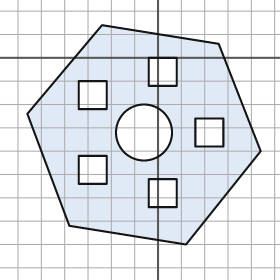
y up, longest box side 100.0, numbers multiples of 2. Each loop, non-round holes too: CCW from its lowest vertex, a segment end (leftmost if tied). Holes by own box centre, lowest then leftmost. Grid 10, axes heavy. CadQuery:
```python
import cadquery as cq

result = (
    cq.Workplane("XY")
    .moveTo(12.0, -80.0)
    .lineTo(44.0, -40.0)
    .lineTo(26.0, 6.0)
    .lineTo(-24.0, 14.0)
    .lineTo(-56.0, -24.0)
    .lineTo(-38.0, -72.0)
    .close()
    .moveTo(-4.0, -64.0)
    .lineTo(8.0, -64.0)
    .lineTo(8.0, -52.0)
    .lineTo(-4.0, -52.0)
    .close()
    .moveTo(-34.0, -54.0)
    .lineTo(-22.0, -54.0)
    .lineTo(-22.0, -42.0)
    .lineTo(-34.0, -42.0)
    .close()
    .moveTo(-6.0, -32.0)
    .circle(12.0)
    .moveTo(16.0, -38.0)
    .lineTo(28.0, -38.0)
    .lineTo(28.0, -26.0)
    .lineTo(16.0, -26.0)
    .close()
    .moveTo(-34.0, -22.0)
    .lineTo(-22.0, -22.0)
    .lineTo(-22.0, -10.0)
    .lineTo(-34.0, -10.0)
    .close()
    .moveTo(-4.0, -12.0)
    .lineTo(8.0, -12.0)
    .lineTo(8.0, 0.0)
    .lineTo(-4.0, 0.0)
    .close()
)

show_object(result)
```